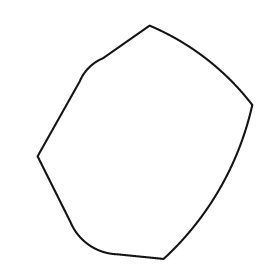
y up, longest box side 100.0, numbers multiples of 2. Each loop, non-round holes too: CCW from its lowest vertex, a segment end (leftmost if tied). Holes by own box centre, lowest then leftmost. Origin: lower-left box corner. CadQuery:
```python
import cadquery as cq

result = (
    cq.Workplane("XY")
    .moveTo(54.0, 0.0)
    .threePointArc((78.0, 30.0), (92.0, 66.0))
    .threePointArc((72.0, 86.0), (48.0, 100.0))
    .lineTo(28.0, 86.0)
    .threePointArc((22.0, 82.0), (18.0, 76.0))
    .lineTo(0.0, 44.0)
    .lineTo(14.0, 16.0)
    .threePointArc((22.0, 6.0), (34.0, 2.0))
    .close()
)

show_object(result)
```